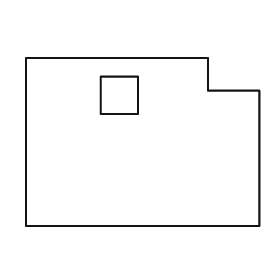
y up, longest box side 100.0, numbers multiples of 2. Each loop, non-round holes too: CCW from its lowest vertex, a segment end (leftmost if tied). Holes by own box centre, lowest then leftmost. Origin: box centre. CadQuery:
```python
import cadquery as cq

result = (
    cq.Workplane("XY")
    .moveTo(-50.0, -36.0)
    .lineTo(50.0, -36.0)
    .lineTo(50.0, 22.0)
    .lineTo(28.0, 22.0)
    .lineTo(28.0, 36.0)
    .lineTo(-50.0, 36.0)
    .close()
    .moveTo(-18.0, 12.0)
    .lineTo(-2.0, 12.0)
    .lineTo(-2.0, 28.0)
    .lineTo(-18.0, 28.0)
    .close()
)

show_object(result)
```